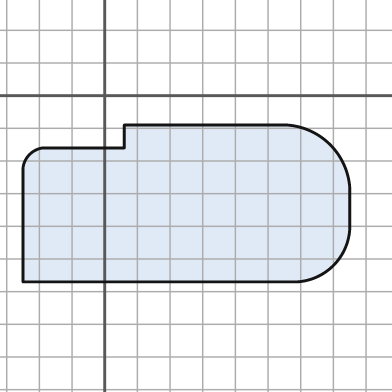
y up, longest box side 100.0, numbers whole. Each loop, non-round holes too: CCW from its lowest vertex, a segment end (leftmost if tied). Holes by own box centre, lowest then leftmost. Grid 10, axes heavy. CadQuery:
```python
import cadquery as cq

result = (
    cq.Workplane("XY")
    .moveTo(-25.0, -57.0)
    .lineTo(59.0, -57.0)
    .threePointArc((70.0, -52.0), (75.0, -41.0))
    .lineTo(75.0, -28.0)
    .threePointArc((69.0, -15.0), (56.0, -9.0))
    .lineTo(6.0, -9.0)
    .lineTo(6.0, -16.0)
    .lineTo(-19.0, -16.0)
    .threePointArc((-23.0, -18.0), (-25.0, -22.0))
    .close()
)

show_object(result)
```